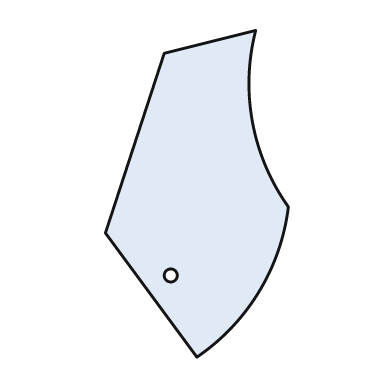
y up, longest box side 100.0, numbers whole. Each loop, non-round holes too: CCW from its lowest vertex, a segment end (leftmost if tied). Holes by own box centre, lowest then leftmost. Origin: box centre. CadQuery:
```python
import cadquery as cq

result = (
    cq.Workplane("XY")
    .moveTo(0.0, -50.0)
    .threePointArc((19.0, -30.0), (28.0, -4.0))
    .threePointArc((17.0, 22.0), (18.0, 50.0))
    .lineTo(-10.0, 43.0)
    .lineTo(-28.0, -12.0)
    .close()
    .moveTo(-8.0, -25.0)
    .circle(2.0)
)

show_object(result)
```